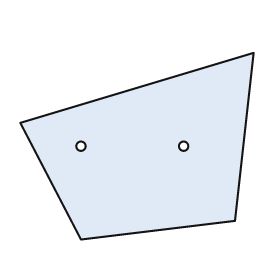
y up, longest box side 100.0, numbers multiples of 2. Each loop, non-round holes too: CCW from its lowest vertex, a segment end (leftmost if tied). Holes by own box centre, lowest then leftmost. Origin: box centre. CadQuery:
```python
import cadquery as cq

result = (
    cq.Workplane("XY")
    .moveTo(-24.0, -40.0)
    .lineTo(42.0, -32.0)
    .lineTo(50.0, 40.0)
    .lineTo(-50.0, 10.0)
    .close()
    .moveTo(-24.0, 0.0)
    .circle(2.0)
    .moveTo(20.0, 0.0)
    .circle(2.0)
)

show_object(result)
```